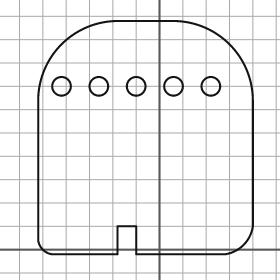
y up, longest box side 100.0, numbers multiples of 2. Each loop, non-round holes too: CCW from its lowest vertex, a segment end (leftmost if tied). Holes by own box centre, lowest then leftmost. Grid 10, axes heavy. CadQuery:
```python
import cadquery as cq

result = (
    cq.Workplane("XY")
    .moveTo(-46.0, -2.0)
    .lineTo(-18.0, -2.0)
    .lineTo(-18.0, 10.0)
    .lineTo(-10.0, 10.0)
    .lineTo(-10.0, -2.0)
    .lineTo(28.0, -2.0)
    .threePointArc((36.0, 2.0), (40.0, 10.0))
    .lineTo(40.0, 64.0)
    .threePointArc((30.0, 88.0), (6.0, 98.0))
    .lineTo(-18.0, 98.0)
    .threePointArc((-42.0, 88.0), (-52.0, 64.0))
    .lineTo(-52.0, 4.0)
    .threePointArc((-50.0, 0.0), (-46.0, -2.0))
    .close()
    .moveTo(-42.0, 70.0)
    .circle(4.0)
    .moveTo(-26.0, 70.0)
    .circle(4.0)
    .moveTo(-10.0, 70.0)
    .circle(4.0)
    .moveTo(6.0, 70.0)
    .circle(4.0)
    .moveTo(22.0, 70.0)
    .circle(4.0)
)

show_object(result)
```